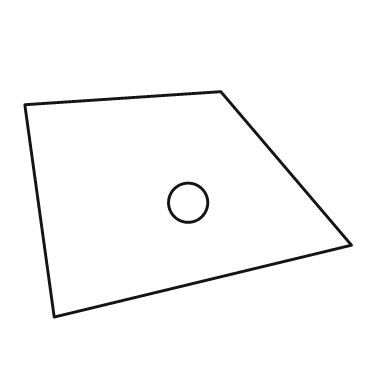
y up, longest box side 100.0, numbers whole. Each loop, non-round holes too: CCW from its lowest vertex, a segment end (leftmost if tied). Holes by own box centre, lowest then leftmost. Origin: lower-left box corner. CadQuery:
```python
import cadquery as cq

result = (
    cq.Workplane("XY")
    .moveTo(9.0, 0.0)
    .lineTo(100.0, 22.0)
    .lineTo(60.0, 69.0)
    .lineTo(0.0, 65.0)
    .close()
    .moveTo(50.0, 35.0)
    .circle(6.0)
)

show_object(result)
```